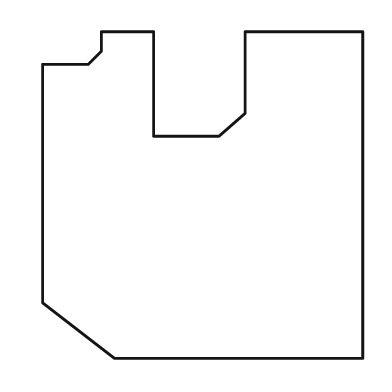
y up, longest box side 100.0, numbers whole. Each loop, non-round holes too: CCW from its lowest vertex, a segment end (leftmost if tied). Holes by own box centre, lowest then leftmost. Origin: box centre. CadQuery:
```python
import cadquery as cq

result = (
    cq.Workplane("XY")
    .moveTo(-27.0, -50.0)
    .lineTo(49.0, -50.0)
    .lineTo(49.0, 50.0)
    .lineTo(13.0, 50.0)
    .lineTo(13.0, 25.0)
    .lineTo(5.0, 18.0)
    .lineTo(-15.0, 18.0)
    .lineTo(-15.0, 50.0)
    .lineTo(-31.0, 50.0)
    .lineTo(-31.0, 44.0)
    .lineTo(-35.0, 40.0)
    .lineTo(-49.0, 40.0)
    .lineTo(-49.0, -33.0)
    .close()
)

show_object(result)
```